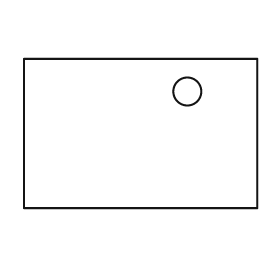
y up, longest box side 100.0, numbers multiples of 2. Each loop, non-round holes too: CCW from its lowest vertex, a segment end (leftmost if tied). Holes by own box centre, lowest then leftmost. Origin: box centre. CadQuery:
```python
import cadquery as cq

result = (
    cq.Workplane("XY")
    .moveTo(-50.0, -32.0)
    .lineTo(50.0, -32.0)
    .lineTo(50.0, 32.0)
    .lineTo(-50.0, 32.0)
    .close()
    .moveTo(20.0, 18.0)
    .circle(6.0)
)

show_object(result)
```